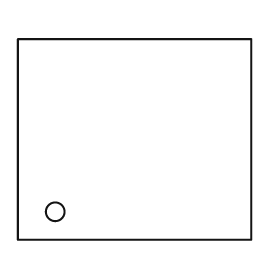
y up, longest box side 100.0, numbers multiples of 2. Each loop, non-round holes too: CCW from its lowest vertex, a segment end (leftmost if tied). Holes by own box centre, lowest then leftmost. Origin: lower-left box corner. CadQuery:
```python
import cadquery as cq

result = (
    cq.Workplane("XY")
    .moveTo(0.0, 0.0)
    .lineTo(100.0, 0.0)
    .lineTo(100.0, 86.0)
    .lineTo(0.0, 86.0)
    .close()
    .moveTo(16.0, 12.0)
    .circle(4.0)
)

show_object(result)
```